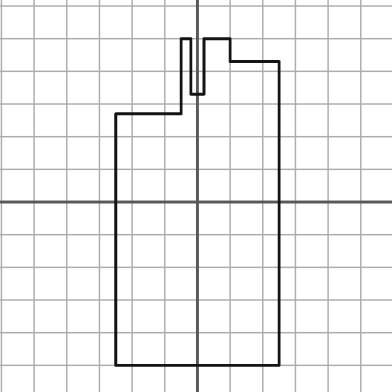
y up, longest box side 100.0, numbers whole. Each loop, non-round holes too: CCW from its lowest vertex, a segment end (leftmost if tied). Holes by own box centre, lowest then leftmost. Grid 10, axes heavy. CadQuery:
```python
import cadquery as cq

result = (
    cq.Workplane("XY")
    .moveTo(-25.0, -50.0)
    .lineTo(25.0, -50.0)
    .lineTo(25.0, 43.0)
    .lineTo(10.0, 43.0)
    .lineTo(10.0, 50.0)
    .lineTo(2.0, 50.0)
    .lineTo(2.0, 33.0)
    .lineTo(-2.0, 33.0)
    .lineTo(-2.0, 50.0)
    .lineTo(-5.0, 50.0)
    .lineTo(-5.0, 27.0)
    .lineTo(-25.0, 27.0)
    .close()
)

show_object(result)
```